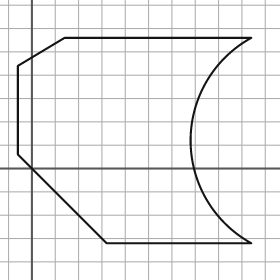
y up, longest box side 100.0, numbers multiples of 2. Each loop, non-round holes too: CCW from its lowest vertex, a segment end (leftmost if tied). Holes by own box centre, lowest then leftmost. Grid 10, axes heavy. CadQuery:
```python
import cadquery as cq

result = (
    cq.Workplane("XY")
    .moveTo(32.0, -32.0)
    .lineTo(94.0, -32.0)
    .threePointArc((68.0, 12.0), (94.0, 56.0))
    .lineTo(14.0, 56.0)
    .lineTo(-6.0, 44.0)
    .lineTo(-6.0, 6.0)
    .close()
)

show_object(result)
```